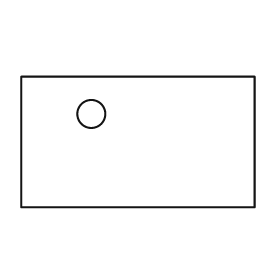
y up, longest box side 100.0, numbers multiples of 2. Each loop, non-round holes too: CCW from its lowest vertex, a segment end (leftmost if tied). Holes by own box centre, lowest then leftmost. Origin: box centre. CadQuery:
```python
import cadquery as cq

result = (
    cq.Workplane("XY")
    .moveTo(-50.0, -28.0)
    .lineTo(50.0, -28.0)
    .lineTo(50.0, 28.0)
    .lineTo(-50.0, 28.0)
    .close()
    .moveTo(-20.0, 12.0)
    .circle(6.0)
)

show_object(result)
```